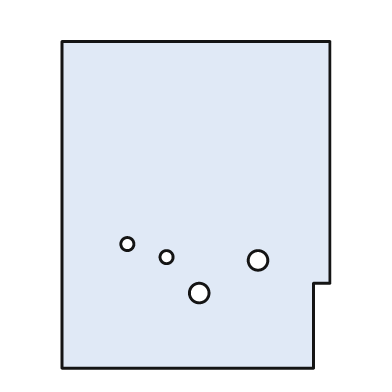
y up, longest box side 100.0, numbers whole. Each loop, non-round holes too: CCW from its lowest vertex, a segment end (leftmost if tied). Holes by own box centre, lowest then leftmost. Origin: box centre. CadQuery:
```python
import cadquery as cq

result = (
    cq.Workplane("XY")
    .moveTo(-41.0, -50.0)
    .lineTo(36.0, -50.0)
    .lineTo(36.0, -24.0)
    .lineTo(41.0, -24.0)
    .lineTo(41.0, 50.0)
    .lineTo(-41.0, 50.0)
    .close()
    .moveTo(1.0, -27.0)
    .circle(3.0)
    .moveTo(19.0, -17.0)
    .circle(3.0)
    .moveTo(-9.0, -16.0)
    .circle(2.0)
    .moveTo(-21.0, -12.0)
    .circle(2.0)
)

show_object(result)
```